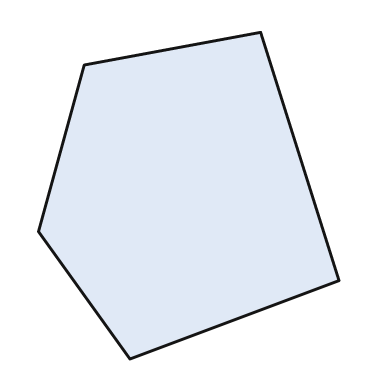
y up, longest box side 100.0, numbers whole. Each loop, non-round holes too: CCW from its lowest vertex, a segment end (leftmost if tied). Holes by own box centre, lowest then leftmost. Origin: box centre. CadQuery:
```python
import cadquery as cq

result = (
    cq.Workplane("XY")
    .moveTo(-18.0, -50.0)
    .lineTo(46.0, -26.0)
    .lineTo(22.0, 50.0)
    .lineTo(-32.0, 40.0)
    .lineTo(-46.0, -11.0)
    .close()
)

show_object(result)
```